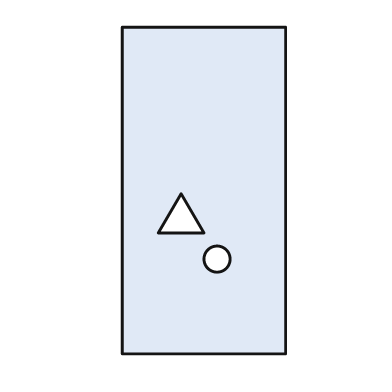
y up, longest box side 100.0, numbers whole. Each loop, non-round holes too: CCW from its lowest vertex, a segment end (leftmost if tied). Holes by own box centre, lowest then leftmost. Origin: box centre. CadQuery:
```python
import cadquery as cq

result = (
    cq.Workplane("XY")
    .moveTo(-25.0, -50.0)
    .lineTo(25.0, -50.0)
    .lineTo(25.0, 50.0)
    .lineTo(-25.0, 50.0)
    .close()
    .moveTo(4.0, -21.0)
    .circle(4.0)
    .moveTo(-14.0, -13.0)
    .lineTo(0.0, -13.0)
    .lineTo(-7.0, -1.0)
    .close()
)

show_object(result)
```